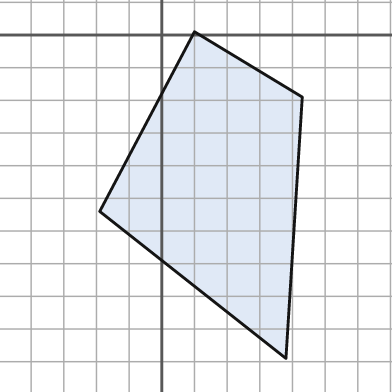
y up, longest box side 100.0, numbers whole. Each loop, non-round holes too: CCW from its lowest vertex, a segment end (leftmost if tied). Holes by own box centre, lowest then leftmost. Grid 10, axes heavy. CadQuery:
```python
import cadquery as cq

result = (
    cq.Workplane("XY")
    .moveTo(38.0, -99.0)
    .lineTo(43.0, -19.0)
    .lineTo(10.0, 1.0)
    .lineTo(-19.0, -54.0)
    .close()
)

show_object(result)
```